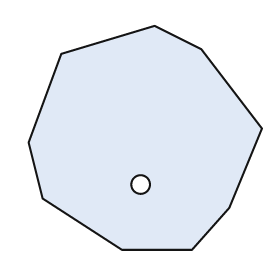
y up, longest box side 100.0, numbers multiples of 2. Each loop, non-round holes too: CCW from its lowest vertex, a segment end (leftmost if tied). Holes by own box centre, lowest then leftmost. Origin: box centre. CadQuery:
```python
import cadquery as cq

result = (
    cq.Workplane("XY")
    .moveTo(-10.0, -48.0)
    .lineTo(20.0, -48.0)
    .lineTo(36.0, -30.0)
    .lineTo(50.0, 4.0)
    .lineTo(24.0, 38.0)
    .lineTo(4.0, 48.0)
    .lineTo(-36.0, 36.0)
    .lineTo(-50.0, -2.0)
    .lineTo(-44.0, -26.0)
    .close()
    .moveTo(-2.0, -20.0)
    .circle(4.0)
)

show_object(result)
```